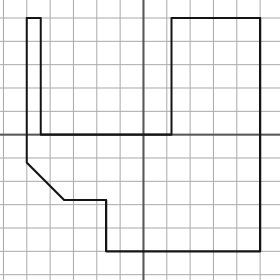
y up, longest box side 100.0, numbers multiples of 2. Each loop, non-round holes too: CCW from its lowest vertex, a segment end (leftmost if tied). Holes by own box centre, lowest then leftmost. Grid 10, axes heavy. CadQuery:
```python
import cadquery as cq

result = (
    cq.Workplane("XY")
    .moveTo(-16.0, -50.0)
    .lineTo(50.0, -50.0)
    .lineTo(50.0, 50.0)
    .lineTo(12.0, 50.0)
    .lineTo(12.0, 0.0)
    .lineTo(-44.0, 0.0)
    .lineTo(-44.0, 50.0)
    .lineTo(-50.0, 50.0)
    .lineTo(-50.0, -12.0)
    .lineTo(-34.0, -28.0)
    .lineTo(-16.0, -28.0)
    .close()
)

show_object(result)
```